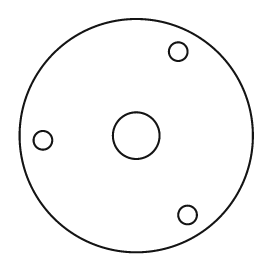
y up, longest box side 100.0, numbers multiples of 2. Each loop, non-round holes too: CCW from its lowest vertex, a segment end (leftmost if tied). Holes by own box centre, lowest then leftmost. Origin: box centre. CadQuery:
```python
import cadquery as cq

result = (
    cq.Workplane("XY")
    .moveTo(0.0, 0.0)
    .circle(50.0)
    .moveTo(22.0, -34.0)
    .circle(4.0)
    .moveTo(-40.0, -2.0)
    .circle(4.0)
    .moveTo(0.0, 0.0)
    .circle(10.0)
    .moveTo(18.0, 36.0)
    .circle(4.0)
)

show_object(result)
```